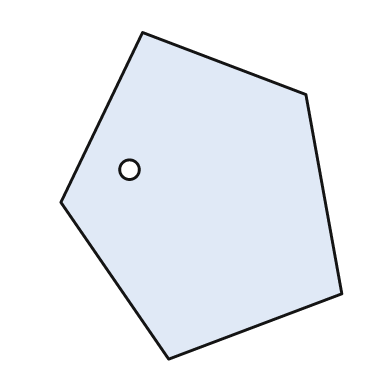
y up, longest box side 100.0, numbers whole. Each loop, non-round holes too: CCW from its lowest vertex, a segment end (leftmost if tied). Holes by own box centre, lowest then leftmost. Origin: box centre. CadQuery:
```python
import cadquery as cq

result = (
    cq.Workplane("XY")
    .moveTo(-10.0, -50.0)
    .lineTo(43.0, -30.0)
    .lineTo(32.0, 31.0)
    .lineTo(-18.0, 50.0)
    .lineTo(-43.0, -2.0)
    .close()
    .moveTo(-22.0, 8.0)
    .circle(3.0)
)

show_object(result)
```